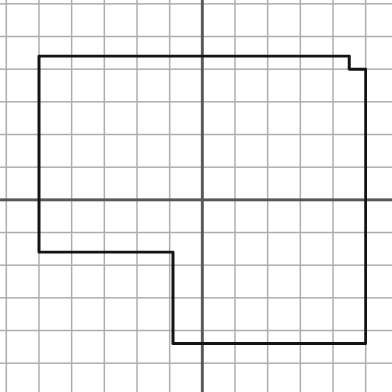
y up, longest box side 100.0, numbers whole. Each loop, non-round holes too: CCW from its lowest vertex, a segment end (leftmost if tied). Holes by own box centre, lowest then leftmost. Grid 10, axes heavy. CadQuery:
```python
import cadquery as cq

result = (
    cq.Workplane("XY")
    .moveTo(-9.0, -44.0)
    .lineTo(50.0, -44.0)
    .lineTo(50.0, 40.0)
    .lineTo(45.0, 40.0)
    .lineTo(45.0, 44.0)
    .lineTo(-50.0, 44.0)
    .lineTo(-50.0, -16.0)
    .lineTo(-9.0, -16.0)
    .close()
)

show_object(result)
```